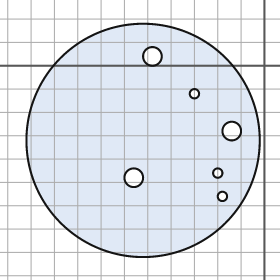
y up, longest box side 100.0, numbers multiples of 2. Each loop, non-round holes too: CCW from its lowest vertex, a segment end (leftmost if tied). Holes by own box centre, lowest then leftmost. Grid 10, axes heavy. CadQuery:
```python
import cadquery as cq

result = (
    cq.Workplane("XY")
    .moveTo(-52.0, -32.0)
    .circle(50.0)
    .moveTo(-18.0, -56.0)
    .circle(2.0)
    .moveTo(-56.0, -48.0)
    .circle(4.0)
    .moveTo(-20.0, -46.0)
    .circle(2.0)
    .moveTo(-14.0, -28.0)
    .circle(4.0)
    .moveTo(-30.0, -12.0)
    .circle(2.0)
    .moveTo(-48.0, 4.0)
    .circle(4.0)
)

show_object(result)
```